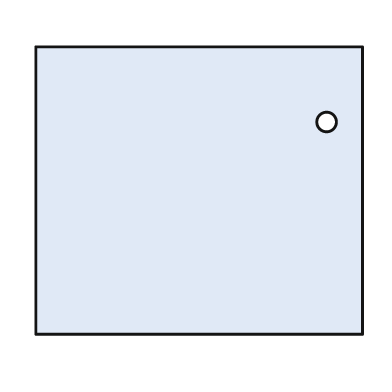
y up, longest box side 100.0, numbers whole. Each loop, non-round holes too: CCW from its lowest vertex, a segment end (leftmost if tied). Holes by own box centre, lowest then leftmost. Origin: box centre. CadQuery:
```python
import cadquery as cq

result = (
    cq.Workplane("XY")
    .moveTo(-50.0, -44.0)
    .lineTo(50.0, -44.0)
    .lineTo(50.0, 44.0)
    .lineTo(-50.0, 44.0)
    .close()
    .moveTo(39.0, 21.0)
    .circle(3.0)
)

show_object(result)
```